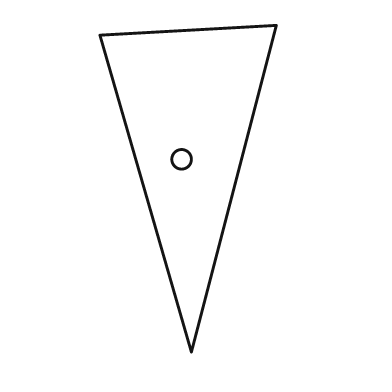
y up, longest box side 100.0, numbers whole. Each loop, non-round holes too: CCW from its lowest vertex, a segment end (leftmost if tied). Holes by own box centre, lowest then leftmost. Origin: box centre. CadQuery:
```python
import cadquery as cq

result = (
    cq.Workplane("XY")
    .moveTo(1.0, -50.0)
    .lineTo(27.0, 50.0)
    .lineTo(-27.0, 47.0)
    .close()
    .moveTo(-2.0, 9.0)
    .circle(3.0)
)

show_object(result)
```